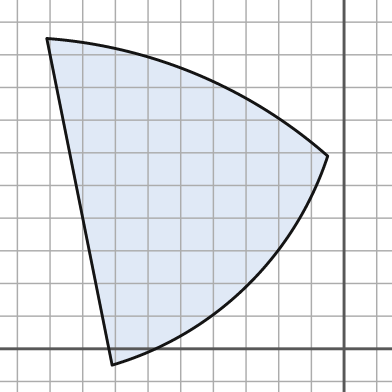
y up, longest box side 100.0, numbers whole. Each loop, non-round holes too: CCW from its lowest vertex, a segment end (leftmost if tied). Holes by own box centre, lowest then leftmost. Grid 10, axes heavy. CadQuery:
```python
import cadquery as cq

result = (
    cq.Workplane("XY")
    .moveTo(-71.0, -5.0)
    .threePointArc((-30.0, 19.0), (-5.0, 59.0))
    .threePointArc((-45.0, 84.0), (-91.0, 95.0))
    .close()
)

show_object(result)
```